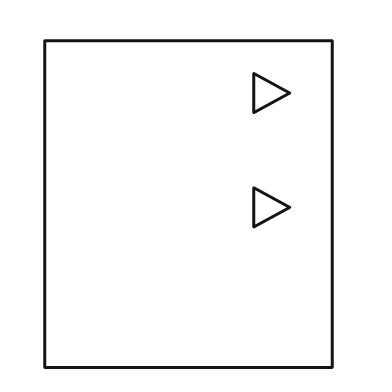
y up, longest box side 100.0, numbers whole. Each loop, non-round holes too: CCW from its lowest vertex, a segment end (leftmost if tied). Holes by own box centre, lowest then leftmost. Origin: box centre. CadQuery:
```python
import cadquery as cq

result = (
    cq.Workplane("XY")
    .moveTo(-44.0, -50.0)
    .lineTo(44.0, -50.0)
    .lineTo(44.0, 50.0)
    .lineTo(-44.0, 50.0)
    .close()
    .moveTo(20.0, -7.0)
    .lineTo(31.0, -1.0)
    .lineTo(20.0, 5.0)
    .close()
    .moveTo(20.0, 28.0)
    .lineTo(31.0, 34.0)
    .lineTo(20.0, 40.0)
    .close()
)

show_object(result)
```